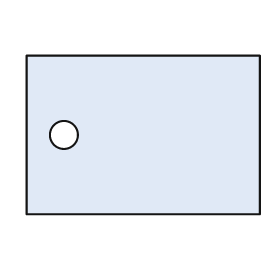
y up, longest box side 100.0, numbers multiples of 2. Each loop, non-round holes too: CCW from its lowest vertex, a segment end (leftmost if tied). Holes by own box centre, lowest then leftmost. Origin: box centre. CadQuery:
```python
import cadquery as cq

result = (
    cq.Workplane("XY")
    .moveTo(-50.0, -34.0)
    .lineTo(50.0, -34.0)
    .lineTo(50.0, 34.0)
    .lineTo(-50.0, 34.0)
    .close()
    .moveTo(-34.0, 0.0)
    .circle(6.0)
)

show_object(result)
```